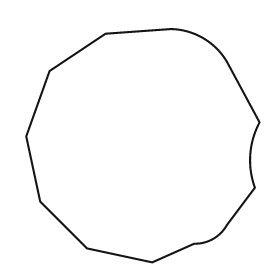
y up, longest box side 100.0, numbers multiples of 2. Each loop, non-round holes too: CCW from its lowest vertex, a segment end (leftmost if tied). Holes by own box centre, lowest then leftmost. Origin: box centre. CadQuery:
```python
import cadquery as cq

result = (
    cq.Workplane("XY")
    .moveTo(4.0, -50.0)
    .lineTo(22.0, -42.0)
    .threePointArc((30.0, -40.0), (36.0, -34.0))
    .lineTo(48.0, -18.0)
    .threePointArc((46.0, -4.0), (50.0, 10.0))
    .lineTo(36.0, 36.0)
    .threePointArc((26.0, 46.0), (12.0, 50.0))
    .lineTo(-16.0, 48.0)
    .lineTo(-40.0, 32.0)
    .lineTo(-50.0, 4.0)
    .lineTo(-44.0, -24.0)
    .lineTo(-24.0, -44.0)
    .close()
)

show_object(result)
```